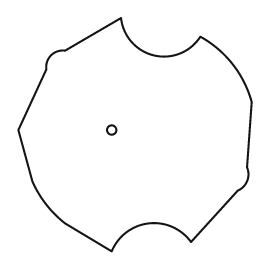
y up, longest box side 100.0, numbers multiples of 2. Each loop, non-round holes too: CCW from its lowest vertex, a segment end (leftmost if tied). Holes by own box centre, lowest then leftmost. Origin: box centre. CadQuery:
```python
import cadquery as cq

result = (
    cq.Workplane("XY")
    .moveTo(-10.0, -50.0)
    .threePointArc((6.0, -38.0), (24.0, -46.0))
    .lineTo(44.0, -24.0)
    .threePointArc((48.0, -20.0), (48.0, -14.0))
    .lineTo(50.0, 14.0)
    .threePointArc((42.0, 30.0), (28.0, 42.0))
    .threePointArc((8.0, 34.0), (-6.0, 50.0))
    .lineTo(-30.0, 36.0)
    .threePointArc((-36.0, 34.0), (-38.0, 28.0))
    .lineTo(-50.0, 2.0)
    .lineTo(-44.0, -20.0)
    .threePointArc((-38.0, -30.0), (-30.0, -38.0))
    .close()
    .moveTo(-10.0, 2.0)
    .circle(2.0)
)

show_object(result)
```